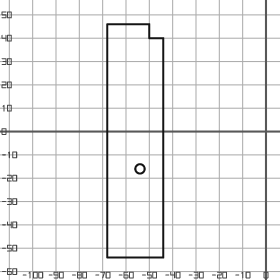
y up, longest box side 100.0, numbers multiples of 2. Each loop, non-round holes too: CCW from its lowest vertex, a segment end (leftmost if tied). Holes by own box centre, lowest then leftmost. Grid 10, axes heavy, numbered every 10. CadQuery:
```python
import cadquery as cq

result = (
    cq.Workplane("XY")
    .moveTo(-68.0, -54.0)
    .lineTo(-44.0, -54.0)
    .lineTo(-44.0, 40.0)
    .lineTo(-50.0, 40.0)
    .lineTo(-50.0, 46.0)
    .lineTo(-68.0, 46.0)
    .close()
    .moveTo(-54.0, -16.0)
    .circle(2.0)
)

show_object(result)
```